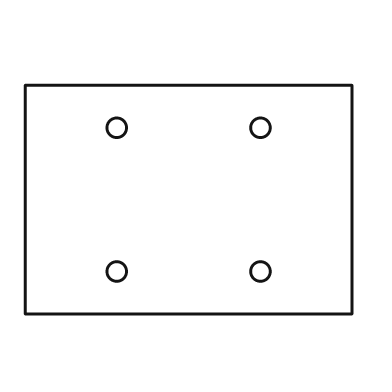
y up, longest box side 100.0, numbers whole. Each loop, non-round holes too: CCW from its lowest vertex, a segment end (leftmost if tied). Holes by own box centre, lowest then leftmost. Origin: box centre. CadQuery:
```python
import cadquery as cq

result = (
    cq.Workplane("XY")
    .moveTo(-50.0, -35.0)
    .lineTo(50.0, -35.0)
    .lineTo(50.0, 35.0)
    .lineTo(-50.0, 35.0)
    .close()
    .moveTo(-22.0, -22.0)
    .circle(3.0)
    .moveTo(22.0, -22.0)
    .circle(3.0)
    .moveTo(-22.0, 22.0)
    .circle(3.0)
    .moveTo(22.0, 22.0)
    .circle(3.0)
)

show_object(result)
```